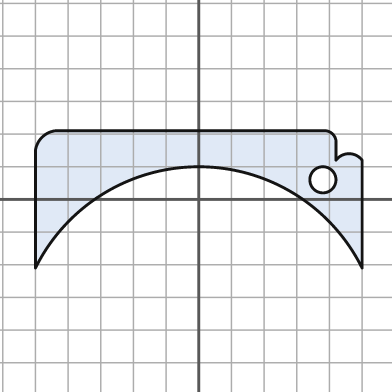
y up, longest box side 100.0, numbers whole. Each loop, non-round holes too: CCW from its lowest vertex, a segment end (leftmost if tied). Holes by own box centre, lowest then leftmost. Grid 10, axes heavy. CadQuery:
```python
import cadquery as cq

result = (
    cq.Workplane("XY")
    .moveTo(-50.0, -21.0)
    .threePointArc((0.0, 10.0), (50.0, -21.0))
    .lineTo(50.0, 12.0)
    .threePointArc((46.0, 14.0), (42.0, 12.0))
    .lineTo(42.0, 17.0)
    .threePointArc((41.0, 20.0), (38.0, 21.0))
    .lineTo(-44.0, 21.0)
    .threePointArc((-48.0, 19.0), (-50.0, 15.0))
    .close()
    .moveTo(38.0, 6.0)
    .circle(4.0)
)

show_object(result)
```